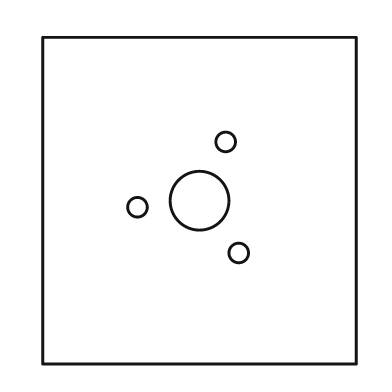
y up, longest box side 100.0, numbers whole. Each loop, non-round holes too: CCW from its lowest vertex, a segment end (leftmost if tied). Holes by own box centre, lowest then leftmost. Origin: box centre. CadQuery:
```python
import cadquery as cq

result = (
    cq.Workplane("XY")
    .moveTo(-48.0, -50.0)
    .lineTo(48.0, -50.0)
    .lineTo(48.0, 50.0)
    .lineTo(-48.0, 50.0)
    .close()
    .moveTo(12.0, -16.0)
    .circle(3.0)
    .moveTo(-19.0, -2.0)
    .circle(3.0)
    .moveTo(0.0, 0.0)
    .circle(9.0)
    .moveTo(8.0, 18.0)
    .circle(3.0)
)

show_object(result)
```